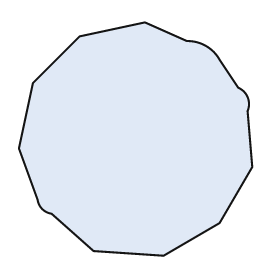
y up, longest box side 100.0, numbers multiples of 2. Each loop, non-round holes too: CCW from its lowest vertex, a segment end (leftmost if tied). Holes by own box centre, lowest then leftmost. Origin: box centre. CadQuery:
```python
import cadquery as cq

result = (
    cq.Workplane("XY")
    .moveTo(12.0, -50.0)
    .lineTo(36.0, -36.0)
    .lineTo(50.0, -12.0)
    .lineTo(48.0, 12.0)
    .threePointArc((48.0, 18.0), (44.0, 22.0))
    .lineTo(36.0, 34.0)
    .threePointArc((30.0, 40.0), (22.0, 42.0))
    .lineTo(4.0, 50.0)
    .lineTo(-24.0, 44.0)
    .lineTo(-44.0, 24.0)
    .lineTo(-50.0, -4.0)
    .lineTo(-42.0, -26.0)
    .threePointArc((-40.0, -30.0), (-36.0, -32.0))
    .lineTo(-18.0, -48.0)
    .close()
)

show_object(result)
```